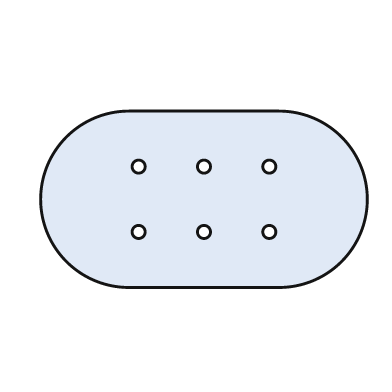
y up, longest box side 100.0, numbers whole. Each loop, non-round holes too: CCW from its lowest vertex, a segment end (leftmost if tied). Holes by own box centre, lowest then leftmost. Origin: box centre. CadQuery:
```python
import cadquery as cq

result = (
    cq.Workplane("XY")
    .moveTo(-23.0, -27.0)
    .lineTo(23.0, -27.0)
    .threePointArc((50.0, 0.0), (23.0, 27.0))
    .lineTo(-23.0, 27.0)
    .threePointArc((-50.0, 0.0), (-23.0, -27.0))
    .close()
    .moveTo(-20.0, -10.0)
    .circle(2.0)
    .moveTo(0.0, -10.0)
    .circle(2.0)
    .moveTo(20.0, -10.0)
    .circle(2.0)
    .moveTo(-20.0, 10.0)
    .circle(2.0)
    .moveTo(0.0, 10.0)
    .circle(2.0)
    .moveTo(20.0, 10.0)
    .circle(2.0)
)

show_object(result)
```